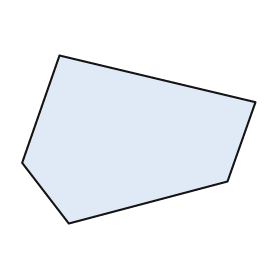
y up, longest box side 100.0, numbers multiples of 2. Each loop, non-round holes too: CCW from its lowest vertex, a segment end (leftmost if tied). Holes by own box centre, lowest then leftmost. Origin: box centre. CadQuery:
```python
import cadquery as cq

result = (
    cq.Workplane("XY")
    .moveTo(-30.0, -36.0)
    .lineTo(38.0, -18.0)
    .lineTo(50.0, 16.0)
    .lineTo(-34.0, 36.0)
    .lineTo(-50.0, -10.0)
    .close()
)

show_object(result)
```